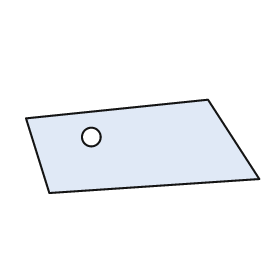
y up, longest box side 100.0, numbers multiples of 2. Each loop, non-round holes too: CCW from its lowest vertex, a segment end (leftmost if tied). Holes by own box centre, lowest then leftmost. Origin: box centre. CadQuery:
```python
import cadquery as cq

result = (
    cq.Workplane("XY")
    .moveTo(-40.0, -20.0)
    .lineTo(50.0, -14.0)
    .lineTo(28.0, 20.0)
    .lineTo(-50.0, 12.0)
    .close()
    .moveTo(-22.0, 4.0)
    .circle(4.0)
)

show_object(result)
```